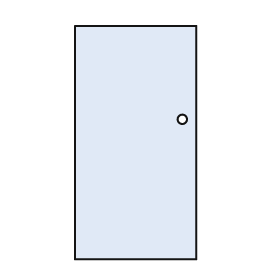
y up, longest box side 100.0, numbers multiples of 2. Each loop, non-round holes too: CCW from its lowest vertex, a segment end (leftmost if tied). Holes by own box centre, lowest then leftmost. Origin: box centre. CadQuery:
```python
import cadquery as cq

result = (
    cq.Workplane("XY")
    .moveTo(-26.0, -50.0)
    .lineTo(26.0, -50.0)
    .lineTo(26.0, 50.0)
    .lineTo(-26.0, 50.0)
    .close()
    .moveTo(20.0, 10.0)
    .circle(2.0)
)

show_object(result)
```